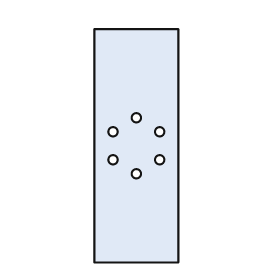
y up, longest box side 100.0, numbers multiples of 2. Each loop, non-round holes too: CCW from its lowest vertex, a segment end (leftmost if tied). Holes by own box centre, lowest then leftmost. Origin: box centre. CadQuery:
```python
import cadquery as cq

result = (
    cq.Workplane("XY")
    .moveTo(-18.0, -50.0)
    .lineTo(18.0, -50.0)
    .lineTo(18.0, 50.0)
    .lineTo(-18.0, 50.0)
    .close()
    .moveTo(0.0, -12.0)
    .circle(2.0)
    .moveTo(-10.0, -6.0)
    .circle(2.0)
    .moveTo(10.0, -6.0)
    .circle(2.0)
    .moveTo(-10.0, 6.0)
    .circle(2.0)
    .moveTo(10.0, 6.0)
    .circle(2.0)
    .moveTo(0.0, 12.0)
    .circle(2.0)
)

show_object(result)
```